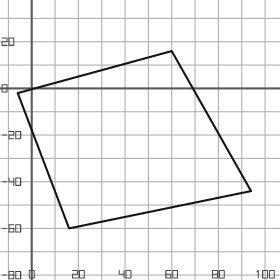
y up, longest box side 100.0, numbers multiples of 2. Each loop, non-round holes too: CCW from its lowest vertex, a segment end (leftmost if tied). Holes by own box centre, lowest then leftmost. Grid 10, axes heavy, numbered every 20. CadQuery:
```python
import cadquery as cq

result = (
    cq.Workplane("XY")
    .moveTo(16.0, -60.0)
    .lineTo(94.0, -44.0)
    .lineTo(60.0, 16.0)
    .lineTo(-6.0, -2.0)
    .close()
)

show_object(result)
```